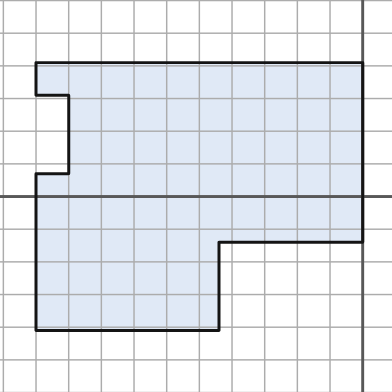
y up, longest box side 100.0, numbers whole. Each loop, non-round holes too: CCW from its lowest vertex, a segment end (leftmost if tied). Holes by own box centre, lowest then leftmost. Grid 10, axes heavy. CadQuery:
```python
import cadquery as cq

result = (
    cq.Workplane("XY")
    .moveTo(-100.0, -41.0)
    .lineTo(-44.0, -41.0)
    .lineTo(-44.0, -14.0)
    .lineTo(0.0, -14.0)
    .lineTo(0.0, 41.0)
    .lineTo(-100.0, 41.0)
    .lineTo(-100.0, 31.0)
    .lineTo(-90.0, 31.0)
    .lineTo(-90.0, 7.0)
    .lineTo(-100.0, 7.0)
    .close()
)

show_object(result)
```